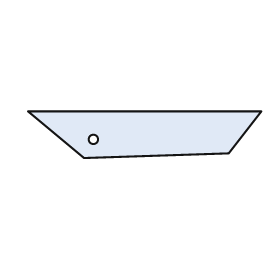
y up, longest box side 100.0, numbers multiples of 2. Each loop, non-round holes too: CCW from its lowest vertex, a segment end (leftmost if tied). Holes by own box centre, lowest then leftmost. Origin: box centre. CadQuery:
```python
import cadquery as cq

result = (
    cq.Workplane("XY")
    .moveTo(-26.0, -10.0)
    .lineTo(36.0, -8.0)
    .lineTo(50.0, 10.0)
    .lineTo(-50.0, 10.0)
    .close()
    .moveTo(-22.0, -2.0)
    .circle(2.0)
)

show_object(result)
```